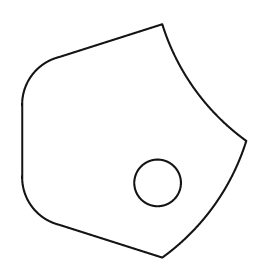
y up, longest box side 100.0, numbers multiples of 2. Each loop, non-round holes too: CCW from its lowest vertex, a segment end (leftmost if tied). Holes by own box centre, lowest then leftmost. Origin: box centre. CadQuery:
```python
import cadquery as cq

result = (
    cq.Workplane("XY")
    .moveTo(12.0, -50.0)
    .threePointArc((34.0, -28.0), (48.0, 0.0))
    .threePointArc((26.0, 22.0), (12.0, 50.0))
    .lineTo(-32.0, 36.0)
    .threePointArc((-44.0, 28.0), (-48.0, 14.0))
    .lineTo(-48.0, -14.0)
    .threePointArc((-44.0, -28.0), (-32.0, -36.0))
    .close()
    .moveTo(10.0, -18.0)
    .circle(10.0)
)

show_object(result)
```